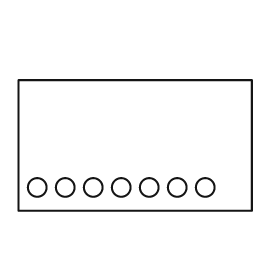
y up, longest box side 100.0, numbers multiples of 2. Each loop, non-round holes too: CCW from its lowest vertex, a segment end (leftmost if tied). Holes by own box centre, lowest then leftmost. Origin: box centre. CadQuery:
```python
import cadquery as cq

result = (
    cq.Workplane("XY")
    .moveTo(-50.0, -28.0)
    .lineTo(50.0, -28.0)
    .lineTo(50.0, 28.0)
    .lineTo(-50.0, 28.0)
    .close()
    .moveTo(-42.0, -18.0)
    .circle(4.0)
    .moveTo(-30.0, -18.0)
    .circle(4.0)
    .moveTo(-18.0, -18.0)
    .circle(4.0)
    .moveTo(-6.0, -18.0)
    .circle(4.0)
    .moveTo(6.0, -18.0)
    .circle(4.0)
    .moveTo(18.0, -18.0)
    .circle(4.0)
    .moveTo(30.0, -18.0)
    .circle(4.0)
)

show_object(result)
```